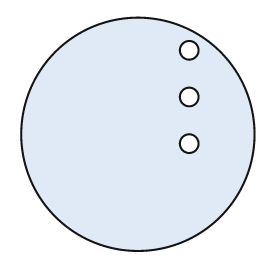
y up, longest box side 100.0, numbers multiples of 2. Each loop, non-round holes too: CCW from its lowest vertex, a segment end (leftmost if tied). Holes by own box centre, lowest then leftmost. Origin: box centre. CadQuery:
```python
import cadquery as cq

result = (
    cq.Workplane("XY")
    .moveTo(0.0, 0.0)
    .circle(50.0)
    .moveTo(22.0, -4.0)
    .circle(4.0)
    .moveTo(22.0, 16.0)
    .circle(4.0)
    .moveTo(22.0, 36.0)
    .circle(4.0)
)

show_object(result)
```